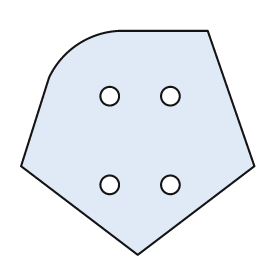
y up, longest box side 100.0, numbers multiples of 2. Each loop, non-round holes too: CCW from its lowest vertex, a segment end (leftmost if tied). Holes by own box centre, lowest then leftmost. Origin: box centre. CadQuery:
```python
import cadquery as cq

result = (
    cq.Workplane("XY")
    .moveTo(0.0, -48.0)
    .lineTo(50.0, -10.0)
    .lineTo(30.0, 48.0)
    .lineTo(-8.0, 48.0)
    .threePointArc((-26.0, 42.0), (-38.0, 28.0))
    .lineTo(-50.0, -10.0)
    .close()
    .moveTo(-12.0, -18.0)
    .circle(4.0)
    .moveTo(14.0, -18.0)
    .circle(4.0)
    .moveTo(-12.0, 20.0)
    .circle(4.0)
    .moveTo(14.0, 20.0)
    .circle(4.0)
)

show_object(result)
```